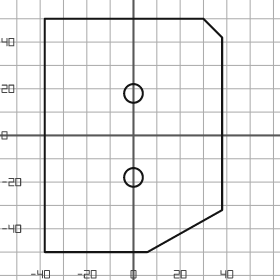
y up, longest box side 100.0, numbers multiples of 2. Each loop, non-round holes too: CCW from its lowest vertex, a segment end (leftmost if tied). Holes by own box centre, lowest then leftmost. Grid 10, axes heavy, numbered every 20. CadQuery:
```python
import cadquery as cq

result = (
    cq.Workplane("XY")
    .moveTo(-38.0, -50.0)
    .lineTo(6.0, -50.0)
    .lineTo(38.0, -32.0)
    .lineTo(38.0, 42.0)
    .lineTo(30.0, 50.0)
    .lineTo(-38.0, 50.0)
    .close()
    .moveTo(0.0, -18.0)
    .circle(4.0)
    .moveTo(0.0, 18.0)
    .circle(4.0)
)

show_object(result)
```